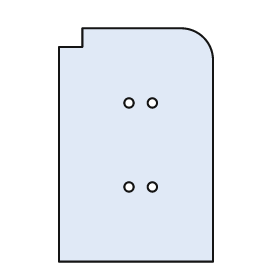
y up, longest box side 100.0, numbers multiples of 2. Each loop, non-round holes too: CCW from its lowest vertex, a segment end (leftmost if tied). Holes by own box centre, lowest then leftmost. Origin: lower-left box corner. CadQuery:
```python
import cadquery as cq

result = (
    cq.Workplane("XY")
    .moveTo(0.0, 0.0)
    .lineTo(66.0, 0.0)
    .lineTo(66.0, 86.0)
    .threePointArc((62.0, 96.0), (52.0, 100.0))
    .lineTo(10.0, 100.0)
    .lineTo(10.0, 92.0)
    .lineTo(0.0, 92.0)
    .close()
    .moveTo(30.0, 32.0)
    .circle(2.0)
    .moveTo(40.0, 32.0)
    .circle(2.0)
    .moveTo(30.0, 68.0)
    .circle(2.0)
    .moveTo(40.0, 68.0)
    .circle(2.0)
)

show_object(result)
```